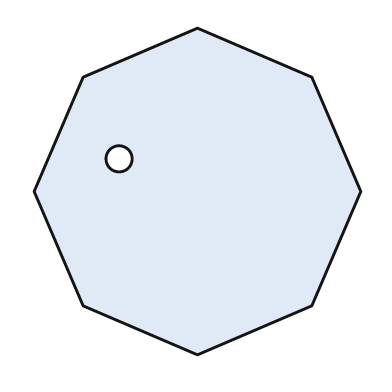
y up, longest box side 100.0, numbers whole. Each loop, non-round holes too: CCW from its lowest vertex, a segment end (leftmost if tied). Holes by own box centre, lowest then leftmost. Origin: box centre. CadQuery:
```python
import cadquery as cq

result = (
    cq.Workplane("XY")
    .moveTo(0.0, -50.0)
    .lineTo(35.0, -35.0)
    .lineTo(50.0, 0.0)
    .lineTo(35.0, 35.0)
    .lineTo(0.0, 50.0)
    .lineTo(-35.0, 35.0)
    .lineTo(-50.0, 0.0)
    .lineTo(-35.0, -35.0)
    .close()
    .moveTo(-24.0, 10.0)
    .circle(4.0)
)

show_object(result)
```